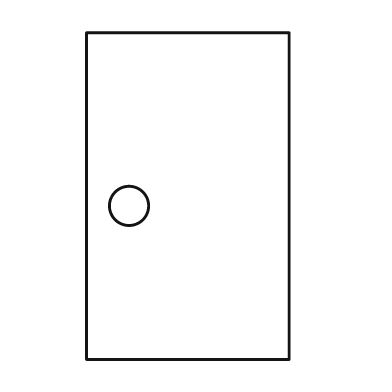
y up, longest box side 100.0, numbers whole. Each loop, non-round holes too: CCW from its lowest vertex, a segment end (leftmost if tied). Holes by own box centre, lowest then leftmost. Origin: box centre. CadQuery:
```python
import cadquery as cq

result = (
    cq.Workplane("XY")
    .moveTo(-31.0, -50.0)
    .lineTo(31.0, -50.0)
    .lineTo(31.0, 50.0)
    .lineTo(-31.0, 50.0)
    .close()
    .moveTo(-18.0, -3.0)
    .circle(6.0)
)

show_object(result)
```